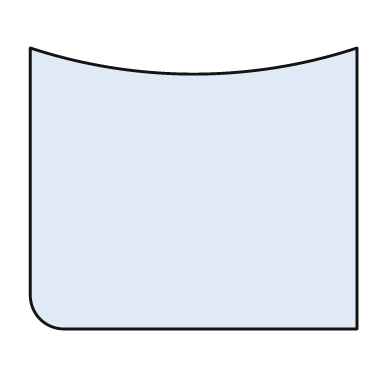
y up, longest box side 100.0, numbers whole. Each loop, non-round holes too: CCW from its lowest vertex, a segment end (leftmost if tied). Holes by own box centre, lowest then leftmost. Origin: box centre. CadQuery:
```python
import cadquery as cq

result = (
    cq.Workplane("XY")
    .moveTo(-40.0, -43.0)
    .lineTo(50.0, -43.0)
    .lineTo(50.0, 43.0)
    .threePointArc((0.0, 35.0), (-50.0, 43.0))
    .lineTo(-50.0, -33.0)
    .threePointArc((-47.0, -40.0), (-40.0, -43.0))
    .close()
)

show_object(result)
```